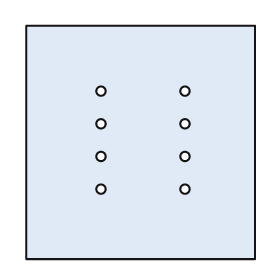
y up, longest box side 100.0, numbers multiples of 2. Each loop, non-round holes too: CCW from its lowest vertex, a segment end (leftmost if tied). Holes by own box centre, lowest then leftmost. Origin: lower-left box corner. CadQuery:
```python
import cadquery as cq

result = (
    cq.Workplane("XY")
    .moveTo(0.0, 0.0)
    .lineTo(98.0, 0.0)
    .lineTo(98.0, 100.0)
    .lineTo(0.0, 100.0)
    .close()
    .moveTo(32.0, 30.0)
    .circle(2.0)
    .moveTo(68.0, 30.0)
    .circle(2.0)
    .moveTo(32.0, 44.0)
    .circle(2.0)
    .moveTo(68.0, 44.0)
    .circle(2.0)
    .moveTo(32.0, 58.0)
    .circle(2.0)
    .moveTo(68.0, 58.0)
    .circle(2.0)
    .moveTo(32.0, 72.0)
    .circle(2.0)
    .moveTo(68.0, 72.0)
    .circle(2.0)
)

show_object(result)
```